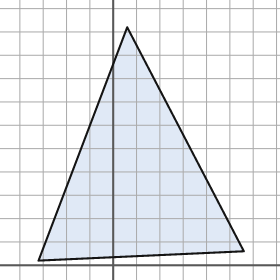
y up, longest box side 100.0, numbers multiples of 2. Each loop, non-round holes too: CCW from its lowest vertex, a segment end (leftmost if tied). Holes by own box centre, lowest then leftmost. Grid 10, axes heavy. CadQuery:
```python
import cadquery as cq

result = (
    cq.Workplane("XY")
    .moveTo(-32.0, 2.0)
    .lineTo(56.0, 6.0)
    .lineTo(6.0, 102.0)
    .close()
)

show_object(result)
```